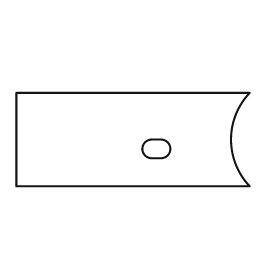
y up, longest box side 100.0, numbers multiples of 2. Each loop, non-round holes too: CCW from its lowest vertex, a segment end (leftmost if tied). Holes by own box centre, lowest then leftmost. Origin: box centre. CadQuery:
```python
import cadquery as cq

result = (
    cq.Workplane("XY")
    .moveTo(-50.0, -20.0)
    .lineTo(50.0, -20.0)
    .threePointArc((42.0, 0.0), (50.0, 20.0))
    .lineTo(-50.0, 20.0)
    .close()
    .moveTo(8.0, -8.0)
    .lineTo(12.0, -8.0)
    .threePointArc((16.0, -4.0), (12.0, 0.0))
    .lineTo(8.0, 0.0)
    .threePointArc((4.0, -4.0), (8.0, -8.0))
    .close()
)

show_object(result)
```